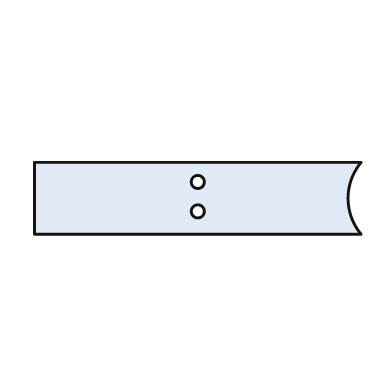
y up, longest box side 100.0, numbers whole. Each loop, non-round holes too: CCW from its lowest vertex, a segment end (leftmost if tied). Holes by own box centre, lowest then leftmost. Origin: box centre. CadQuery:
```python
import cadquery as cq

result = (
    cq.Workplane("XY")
    .moveTo(-50.0, -11.0)
    .lineTo(50.0, -11.0)
    .threePointArc((46.0, 0.0), (50.0, 11.0))
    .lineTo(-50.0, 11.0)
    .close()
    .moveTo(0.0, -4.0)
    .circle(2.0)
    .moveTo(0.0, 5.0)
    .circle(2.0)
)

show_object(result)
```